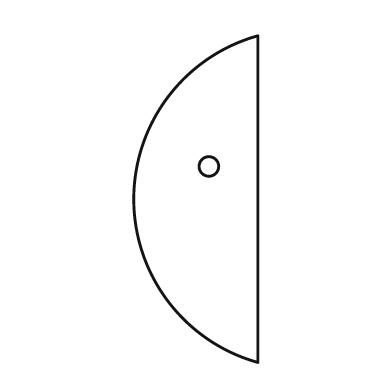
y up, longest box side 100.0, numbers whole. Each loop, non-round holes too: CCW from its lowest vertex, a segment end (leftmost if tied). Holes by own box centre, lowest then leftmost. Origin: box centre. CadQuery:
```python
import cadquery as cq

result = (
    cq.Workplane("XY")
    .moveTo(19.0, -50.0)
    .lineTo(19.0, 50.0)
    .threePointArc((-19.0, 0.0), (19.0, -50.0))
    .close()
    .moveTo(4.0, 10.0)
    .circle(3.0)
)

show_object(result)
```